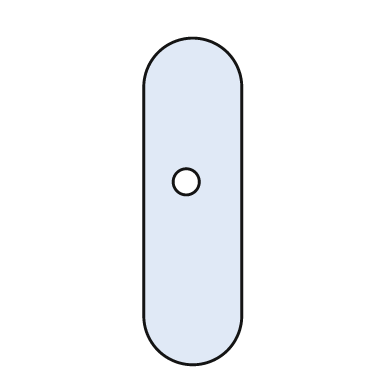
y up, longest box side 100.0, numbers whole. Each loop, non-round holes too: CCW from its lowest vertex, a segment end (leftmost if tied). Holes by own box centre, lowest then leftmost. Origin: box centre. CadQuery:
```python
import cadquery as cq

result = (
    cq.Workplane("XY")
    .moveTo(-15.0, -35.0)
    .threePointArc((0.0, -50.0), (15.0, -35.0))
    .lineTo(15.0, 35.0)
    .threePointArc((0.0, 50.0), (-15.0, 35.0))
    .close()
    .moveTo(-2.0, 6.0)
    .circle(4.0)
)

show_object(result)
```